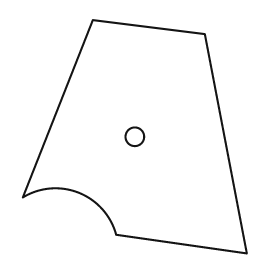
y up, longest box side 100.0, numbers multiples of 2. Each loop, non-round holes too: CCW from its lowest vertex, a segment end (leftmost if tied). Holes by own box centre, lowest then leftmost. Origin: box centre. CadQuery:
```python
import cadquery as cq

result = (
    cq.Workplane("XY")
    .moveTo(48.0, -50.0)
    .lineTo(30.0, 44.0)
    .lineTo(-18.0, 50.0)
    .lineTo(-48.0, -26.0)
    .threePointArc((-24.0, -24.0), (-8.0, -42.0))
    .close()
    .moveTo(0.0, 0.0)
    .circle(4.0)
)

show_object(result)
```